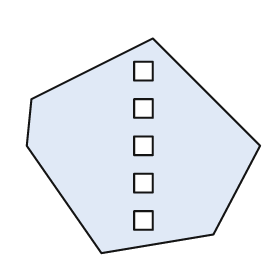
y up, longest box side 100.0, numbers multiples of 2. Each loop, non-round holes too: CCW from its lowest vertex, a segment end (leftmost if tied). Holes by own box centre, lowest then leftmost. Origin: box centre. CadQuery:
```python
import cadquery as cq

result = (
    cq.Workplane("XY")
    .moveTo(-18.0, -46.0)
    .lineTo(30.0, -38.0)
    .lineTo(50.0, 0.0)
    .lineTo(4.0, 46.0)
    .lineTo(-48.0, 20.0)
    .lineTo(-50.0, 0.0)
    .close()
    .moveTo(-4.0, -36.0)
    .lineTo(4.0, -36.0)
    .lineTo(4.0, -28.0)
    .lineTo(-4.0, -28.0)
    .close()
    .moveTo(-4.0, -20.0)
    .lineTo(4.0, -20.0)
    .lineTo(4.0, -12.0)
    .lineTo(-4.0, -12.0)
    .close()
    .moveTo(-4.0, -4.0)
    .lineTo(4.0, -4.0)
    .lineTo(4.0, 4.0)
    .lineTo(-4.0, 4.0)
    .close()
    .moveTo(-4.0, 12.0)
    .lineTo(4.0, 12.0)
    .lineTo(4.0, 20.0)
    .lineTo(-4.0, 20.0)
    .close()
    .moveTo(-4.0, 28.0)
    .lineTo(4.0, 28.0)
    .lineTo(4.0, 36.0)
    .lineTo(-4.0, 36.0)
    .close()
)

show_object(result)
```